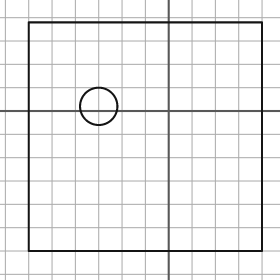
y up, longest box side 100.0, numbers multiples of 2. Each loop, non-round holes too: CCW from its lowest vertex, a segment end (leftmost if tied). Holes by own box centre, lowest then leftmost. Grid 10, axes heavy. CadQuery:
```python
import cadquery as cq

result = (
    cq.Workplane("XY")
    .moveTo(-60.0, -60.0)
    .lineTo(40.0, -60.0)
    .lineTo(40.0, 38.0)
    .lineTo(-60.0, 38.0)
    .close()
    .moveTo(-30.0, 2.0)
    .circle(8.0)
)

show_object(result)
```